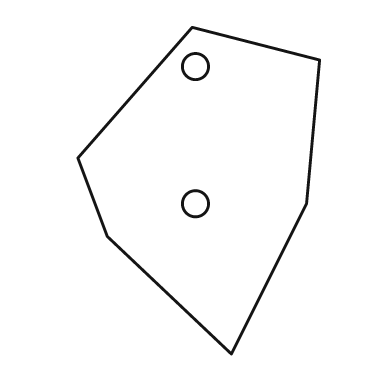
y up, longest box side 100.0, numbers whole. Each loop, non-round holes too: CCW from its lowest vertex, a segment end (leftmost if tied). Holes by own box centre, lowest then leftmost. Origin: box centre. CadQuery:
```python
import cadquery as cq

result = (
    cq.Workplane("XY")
    .moveTo(10.0, -50.0)
    .lineTo(33.0, -4.0)
    .lineTo(37.0, 40.0)
    .lineTo(-2.0, 50.0)
    .lineTo(-37.0, 10.0)
    .lineTo(-28.0, -14.0)
    .close()
    .moveTo(-1.0, -4.0)
    .circle(4.0)
    .moveTo(-1.0, 38.0)
    .circle(4.0)
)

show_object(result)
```